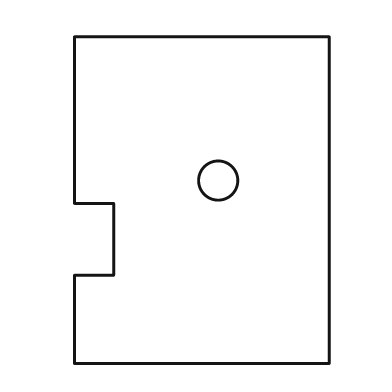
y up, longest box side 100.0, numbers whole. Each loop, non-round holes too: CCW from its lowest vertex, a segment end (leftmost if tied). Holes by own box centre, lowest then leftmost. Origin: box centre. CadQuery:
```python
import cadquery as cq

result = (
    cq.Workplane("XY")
    .moveTo(-39.0, -50.0)
    .lineTo(39.0, -50.0)
    .lineTo(39.0, 50.0)
    .lineTo(-39.0, 50.0)
    .lineTo(-39.0, -1.0)
    .lineTo(-27.0, -1.0)
    .lineTo(-27.0, -23.0)
    .lineTo(-39.0, -23.0)
    .close()
    .moveTo(5.0, 6.0)
    .circle(6.0)
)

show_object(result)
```